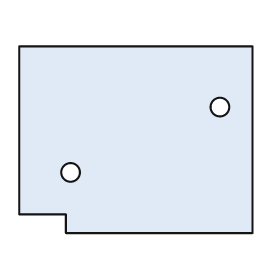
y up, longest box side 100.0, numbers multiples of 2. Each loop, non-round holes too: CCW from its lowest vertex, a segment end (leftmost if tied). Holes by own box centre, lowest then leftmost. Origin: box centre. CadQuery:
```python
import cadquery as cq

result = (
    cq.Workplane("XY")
    .moveTo(-30.0, -40.0)
    .lineTo(50.0, -40.0)
    .lineTo(50.0, 40.0)
    .lineTo(-50.0, 40.0)
    .lineTo(-50.0, -32.0)
    .lineTo(-30.0, -32.0)
    .close()
    .moveTo(-28.0, -14.0)
    .circle(4.0)
    .moveTo(36.0, 14.0)
    .circle(4.0)
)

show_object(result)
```